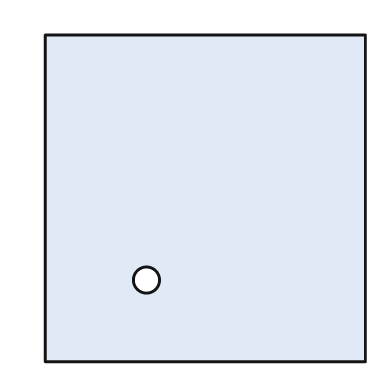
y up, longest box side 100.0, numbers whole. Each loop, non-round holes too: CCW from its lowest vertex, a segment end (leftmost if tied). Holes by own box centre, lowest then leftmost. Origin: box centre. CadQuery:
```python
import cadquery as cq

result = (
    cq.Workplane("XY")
    .moveTo(-49.0, -50.0)
    .lineTo(49.0, -50.0)
    .lineTo(49.0, 50.0)
    .lineTo(-49.0, 50.0)
    .close()
    .moveTo(-18.0, -25.0)
    .circle(4.0)
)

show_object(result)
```